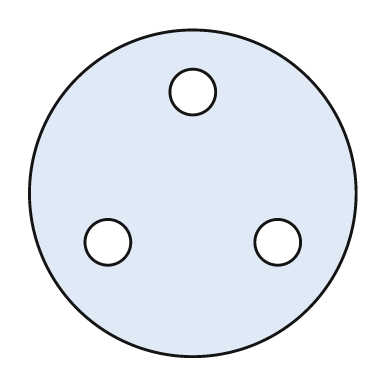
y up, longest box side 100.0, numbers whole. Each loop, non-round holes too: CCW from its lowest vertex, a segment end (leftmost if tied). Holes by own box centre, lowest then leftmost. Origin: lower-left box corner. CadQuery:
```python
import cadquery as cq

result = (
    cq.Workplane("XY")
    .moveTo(50.0, 50.0)
    .circle(50.0)
    .moveTo(24.0, 35.0)
    .circle(7.0)
    .moveTo(76.0, 35.0)
    .circle(7.0)
    .moveTo(50.0, 81.0)
    .circle(7.0)
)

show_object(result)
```